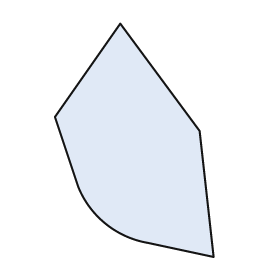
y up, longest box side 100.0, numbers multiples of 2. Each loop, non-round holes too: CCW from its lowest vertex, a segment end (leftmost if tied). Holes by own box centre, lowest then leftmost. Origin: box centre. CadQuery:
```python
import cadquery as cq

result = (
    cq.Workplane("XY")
    .moveTo(34.0, -50.0)
    .lineTo(28.0, 4.0)
    .lineTo(-6.0, 50.0)
    .lineTo(-34.0, 10.0)
    .lineTo(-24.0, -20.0)
    .threePointArc((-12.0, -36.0), (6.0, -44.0))
    .close()
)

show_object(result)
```